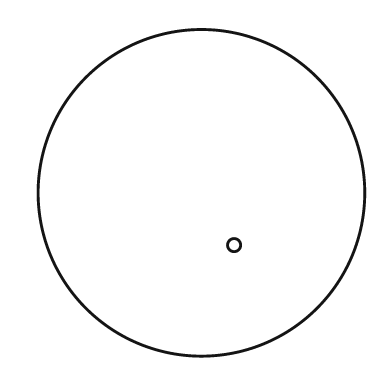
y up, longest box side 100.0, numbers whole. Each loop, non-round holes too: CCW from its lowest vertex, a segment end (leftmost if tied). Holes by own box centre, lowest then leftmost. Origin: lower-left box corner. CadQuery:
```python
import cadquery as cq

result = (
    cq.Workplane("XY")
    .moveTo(50.0, 50.0)
    .circle(50.0)
    .moveTo(60.0, 34.0)
    .circle(2.0)
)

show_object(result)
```